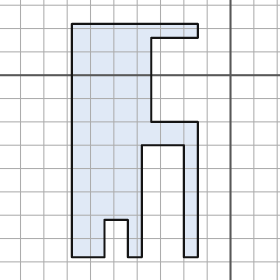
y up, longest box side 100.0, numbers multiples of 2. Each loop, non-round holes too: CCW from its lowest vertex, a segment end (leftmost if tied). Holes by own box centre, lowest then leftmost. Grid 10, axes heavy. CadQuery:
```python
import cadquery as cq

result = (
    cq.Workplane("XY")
    .moveTo(-68.0, -78.0)
    .lineTo(-54.0, -78.0)
    .lineTo(-54.0, -62.0)
    .lineTo(-44.0, -62.0)
    .lineTo(-44.0, -78.0)
    .lineTo(-38.0, -78.0)
    .lineTo(-38.0, -30.0)
    .lineTo(-20.0, -30.0)
    .lineTo(-20.0, -78.0)
    .lineTo(-14.0, -78.0)
    .lineTo(-14.0, -20.0)
    .lineTo(-34.0, -20.0)
    .lineTo(-34.0, 16.0)
    .lineTo(-14.0, 16.0)
    .lineTo(-14.0, 22.0)
    .lineTo(-68.0, 22.0)
    .close()
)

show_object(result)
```